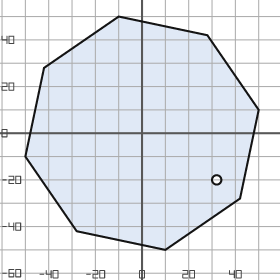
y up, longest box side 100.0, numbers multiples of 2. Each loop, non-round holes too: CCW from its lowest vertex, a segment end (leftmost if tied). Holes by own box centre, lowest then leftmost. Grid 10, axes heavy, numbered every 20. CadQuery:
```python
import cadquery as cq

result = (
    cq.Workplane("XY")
    .moveTo(10.0, -50.0)
    .lineTo(42.0, -28.0)
    .lineTo(50.0, 10.0)
    .lineTo(28.0, 42.0)
    .lineTo(-10.0, 50.0)
    .lineTo(-42.0, 28.0)
    .lineTo(-50.0, -10.0)
    .lineTo(-28.0, -42.0)
    .close()
    .moveTo(32.0, -20.0)
    .circle(2.0)
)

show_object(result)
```